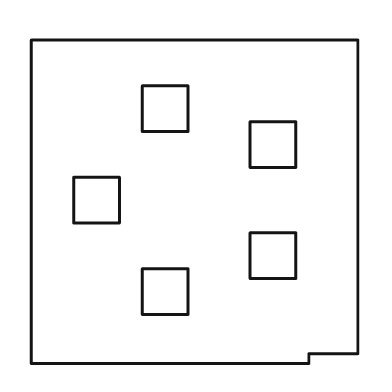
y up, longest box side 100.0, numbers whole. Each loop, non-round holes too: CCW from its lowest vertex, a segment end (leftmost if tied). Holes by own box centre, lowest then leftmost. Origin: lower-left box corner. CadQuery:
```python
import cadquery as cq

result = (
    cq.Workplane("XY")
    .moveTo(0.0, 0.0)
    .lineTo(85.0, 0.0)
    .lineTo(85.0, 3.0)
    .lineTo(100.0, 3.0)
    .lineTo(100.0, 99.0)
    .lineTo(0.0, 99.0)
    .close()
    .moveTo(34.0, 15.0)
    .lineTo(48.0, 15.0)
    .lineTo(48.0, 29.0)
    .lineTo(34.0, 29.0)
    .close()
    .moveTo(67.0, 26.0)
    .lineTo(81.0, 26.0)
    .lineTo(81.0, 40.0)
    .lineTo(67.0, 40.0)
    .close()
    .moveTo(13.0, 43.0)
    .lineTo(27.0, 43.0)
    .lineTo(27.0, 57.0)
    .lineTo(13.0, 57.0)
    .close()
    .moveTo(67.0, 60.0)
    .lineTo(81.0, 60.0)
    .lineTo(81.0, 74.0)
    .lineTo(67.0, 74.0)
    .close()
    .moveTo(34.0, 71.0)
    .lineTo(48.0, 71.0)
    .lineTo(48.0, 85.0)
    .lineTo(34.0, 85.0)
    .close()
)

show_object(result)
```